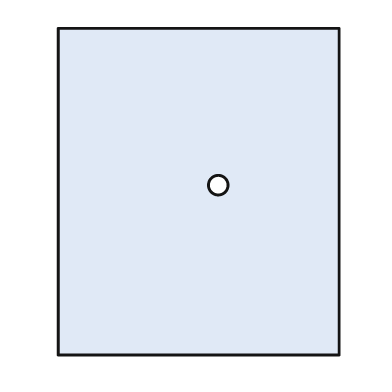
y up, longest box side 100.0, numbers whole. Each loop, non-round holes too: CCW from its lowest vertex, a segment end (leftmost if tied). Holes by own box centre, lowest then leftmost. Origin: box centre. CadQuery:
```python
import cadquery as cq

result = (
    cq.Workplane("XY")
    .moveTo(-43.0, -50.0)
    .lineTo(43.0, -50.0)
    .lineTo(43.0, 50.0)
    .lineTo(-43.0, 50.0)
    .close()
    .moveTo(6.0, 2.0)
    .circle(3.0)
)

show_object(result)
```